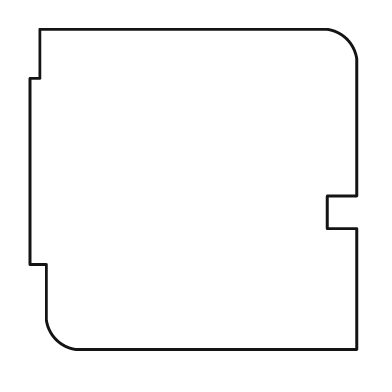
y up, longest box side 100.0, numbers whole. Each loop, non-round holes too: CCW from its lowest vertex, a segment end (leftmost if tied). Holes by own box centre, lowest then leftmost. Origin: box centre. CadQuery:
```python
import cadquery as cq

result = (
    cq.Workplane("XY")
    .moveTo(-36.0, -49.0)
    .lineTo(50.0, -49.0)
    .lineTo(50.0, -12.0)
    .lineTo(41.0, -12.0)
    .lineTo(41.0, -2.0)
    .lineTo(50.0, -2.0)
    .lineTo(50.0, 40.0)
    .threePointArc((47.0, 46.0), (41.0, 49.0))
    .lineTo(-47.0, 49.0)
    .lineTo(-47.0, 34.0)
    .lineTo(-50.0, 34.0)
    .lineTo(-50.0, -23.0)
    .lineTo(-45.0, -23.0)
    .lineTo(-45.0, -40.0)
    .threePointArc((-42.0, -46.0), (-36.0, -49.0))
    .close()
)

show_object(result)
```